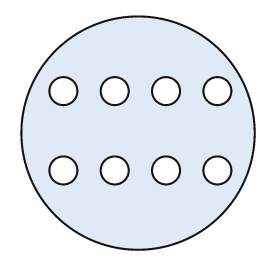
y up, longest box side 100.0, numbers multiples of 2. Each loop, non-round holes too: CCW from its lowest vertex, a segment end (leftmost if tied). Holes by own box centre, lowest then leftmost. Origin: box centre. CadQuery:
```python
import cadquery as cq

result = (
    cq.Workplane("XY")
    .moveTo(0.0, 0.0)
    .circle(50.0)
    .moveTo(-32.0, -16.0)
    .circle(6.0)
    .moveTo(-10.0, -16.0)
    .circle(6.0)
    .moveTo(12.0, -16.0)
    .circle(6.0)
    .moveTo(34.0, -16.0)
    .circle(6.0)
    .moveTo(-32.0, 18.0)
    .circle(6.0)
    .moveTo(-10.0, 18.0)
    .circle(6.0)
    .moveTo(12.0, 18.0)
    .circle(6.0)
    .moveTo(34.0, 18.0)
    .circle(6.0)
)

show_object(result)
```